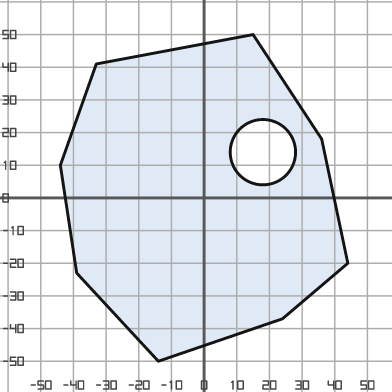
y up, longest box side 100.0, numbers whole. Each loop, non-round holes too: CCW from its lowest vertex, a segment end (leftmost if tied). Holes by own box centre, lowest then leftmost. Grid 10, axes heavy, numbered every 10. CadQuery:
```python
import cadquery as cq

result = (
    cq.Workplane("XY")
    .moveTo(-14.0, -50.0)
    .lineTo(24.0, -37.0)
    .lineTo(44.0, -20.0)
    .lineTo(36.0, 18.0)
    .lineTo(15.0, 50.0)
    .lineTo(-33.0, 41.0)
    .lineTo(-44.0, 10.0)
    .lineTo(-39.0, -23.0)
    .close()
    .moveTo(18.0, 14.0)
    .circle(10.0)
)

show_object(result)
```